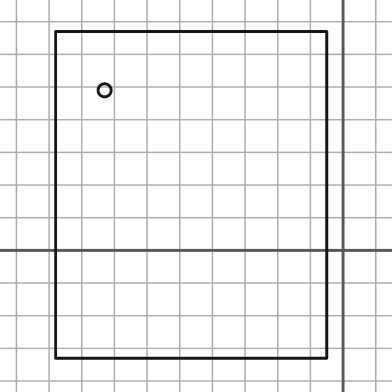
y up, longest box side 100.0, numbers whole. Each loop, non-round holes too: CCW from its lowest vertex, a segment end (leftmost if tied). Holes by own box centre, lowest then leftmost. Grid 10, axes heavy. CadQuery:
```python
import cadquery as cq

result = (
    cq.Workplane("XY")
    .moveTo(-88.0, -33.0)
    .lineTo(-5.0, -33.0)
    .lineTo(-5.0, 67.0)
    .lineTo(-88.0, 67.0)
    .close()
    .moveTo(-73.0, 49.0)
    .circle(2.0)
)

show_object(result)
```